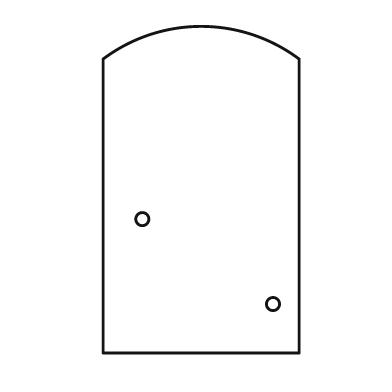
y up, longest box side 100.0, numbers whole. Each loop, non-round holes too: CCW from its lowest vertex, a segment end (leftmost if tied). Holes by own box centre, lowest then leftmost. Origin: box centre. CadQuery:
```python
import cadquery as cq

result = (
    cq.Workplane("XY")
    .moveTo(-30.0, -50.0)
    .lineTo(30.0, -50.0)
    .lineTo(30.0, 40.0)
    .threePointArc((0.0, 50.0), (-30.0, 40.0))
    .close()
    .moveTo(22.0, -35.0)
    .circle(2.0)
    .moveTo(-18.0, -9.0)
    .circle(2.0)
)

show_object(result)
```